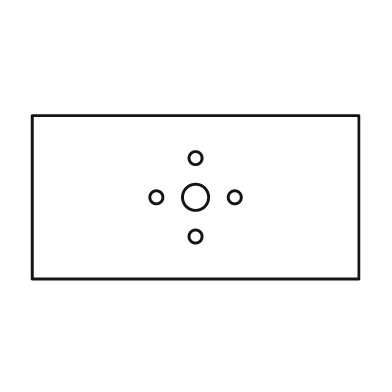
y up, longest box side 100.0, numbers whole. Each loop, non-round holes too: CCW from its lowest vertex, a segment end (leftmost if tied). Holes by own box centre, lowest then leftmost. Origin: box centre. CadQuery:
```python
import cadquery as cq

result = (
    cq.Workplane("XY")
    .moveTo(-50.0, -25.0)
    .lineTo(50.0, -25.0)
    .lineTo(50.0, 25.0)
    .lineTo(-50.0, 25.0)
    .close()
    .moveTo(0.0, -12.0)
    .circle(2.0)
    .moveTo(-12.0, 0.0)
    .circle(2.0)
    .moveTo(0.0, 0.0)
    .circle(4.0)
    .moveTo(12.0, 0.0)
    .circle(2.0)
    .moveTo(0.0, 12.0)
    .circle(2.0)
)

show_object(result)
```